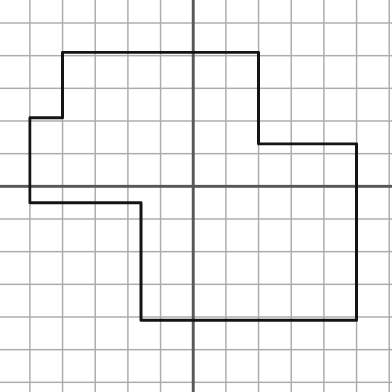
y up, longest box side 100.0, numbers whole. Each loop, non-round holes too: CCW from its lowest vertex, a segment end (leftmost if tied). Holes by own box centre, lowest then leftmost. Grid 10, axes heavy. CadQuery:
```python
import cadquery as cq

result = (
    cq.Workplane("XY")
    .moveTo(-16.0, -41.0)
    .lineTo(50.0, -41.0)
    .lineTo(50.0, 13.0)
    .lineTo(20.0, 13.0)
    .lineTo(20.0, 41.0)
    .lineTo(-40.0, 41.0)
    .lineTo(-40.0, 21.0)
    .lineTo(-50.0, 21.0)
    .lineTo(-50.0, -5.0)
    .lineTo(-16.0, -5.0)
    .close()
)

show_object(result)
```